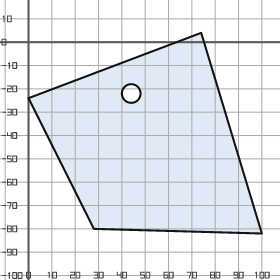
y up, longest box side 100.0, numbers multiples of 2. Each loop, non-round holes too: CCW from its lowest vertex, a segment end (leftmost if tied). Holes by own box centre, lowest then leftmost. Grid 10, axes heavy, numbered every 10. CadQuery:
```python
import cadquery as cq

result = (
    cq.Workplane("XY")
    .moveTo(100.0, -82.0)
    .lineTo(74.0, 4.0)
    .lineTo(0.0, -24.0)
    .lineTo(28.0, -80.0)
    .close()
    .moveTo(44.0, -22.0)
    .circle(4.0)
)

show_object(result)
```